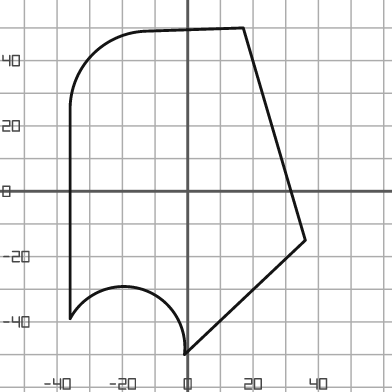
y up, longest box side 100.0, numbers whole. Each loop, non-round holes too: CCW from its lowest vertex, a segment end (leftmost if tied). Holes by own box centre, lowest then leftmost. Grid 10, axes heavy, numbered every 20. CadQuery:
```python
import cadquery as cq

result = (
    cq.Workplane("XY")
    .moveTo(-1.0, -50.0)
    .lineTo(36.0, -15.0)
    .lineTo(17.0, 50.0)
    .lineTo(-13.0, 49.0)
    .threePointArc((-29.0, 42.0), (-36.0, 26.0))
    .lineTo(-36.0, -39.0)
    .threePointArc((-14.0, -30.0), (-1.0, -50.0))
    .close()
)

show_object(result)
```